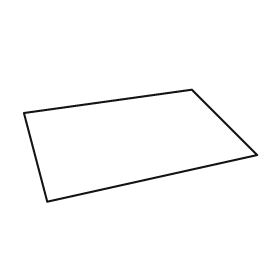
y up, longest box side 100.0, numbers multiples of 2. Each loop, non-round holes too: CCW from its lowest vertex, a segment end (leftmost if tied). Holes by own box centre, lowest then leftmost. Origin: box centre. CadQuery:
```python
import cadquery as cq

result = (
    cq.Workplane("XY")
    .moveTo(-40.0, -24.0)
    .lineTo(50.0, -4.0)
    .lineTo(22.0, 24.0)
    .lineTo(-50.0, 14.0)
    .close()
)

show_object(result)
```